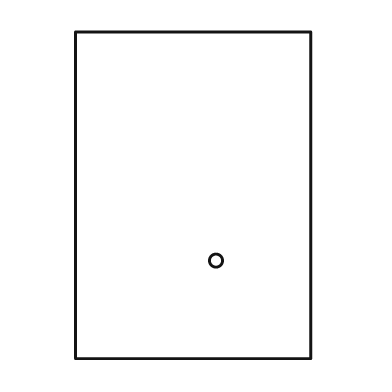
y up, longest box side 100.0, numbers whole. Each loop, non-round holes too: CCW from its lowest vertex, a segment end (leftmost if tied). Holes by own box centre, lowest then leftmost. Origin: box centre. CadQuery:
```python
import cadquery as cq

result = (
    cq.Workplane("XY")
    .moveTo(-36.0, -50.0)
    .lineTo(36.0, -50.0)
    .lineTo(36.0, 50.0)
    .lineTo(-36.0, 50.0)
    .close()
    .moveTo(7.0, -20.0)
    .circle(2.0)
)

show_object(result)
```